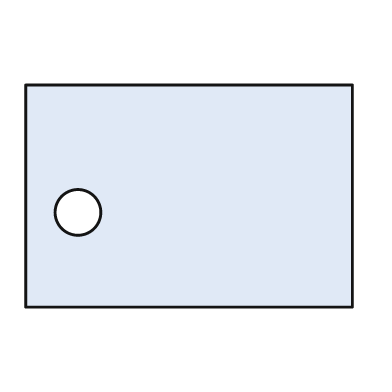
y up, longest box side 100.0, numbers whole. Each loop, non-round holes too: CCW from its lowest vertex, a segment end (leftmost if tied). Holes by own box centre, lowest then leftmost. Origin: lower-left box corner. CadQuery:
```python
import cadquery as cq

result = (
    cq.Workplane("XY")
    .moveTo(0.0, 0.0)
    .lineTo(100.0, 0.0)
    .lineTo(100.0, 68.0)
    .lineTo(0.0, 68.0)
    .close()
    .moveTo(16.0, 29.0)
    .circle(7.0)
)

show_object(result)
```